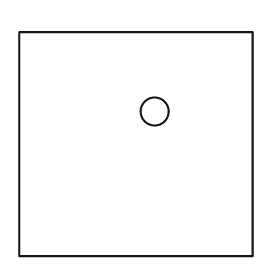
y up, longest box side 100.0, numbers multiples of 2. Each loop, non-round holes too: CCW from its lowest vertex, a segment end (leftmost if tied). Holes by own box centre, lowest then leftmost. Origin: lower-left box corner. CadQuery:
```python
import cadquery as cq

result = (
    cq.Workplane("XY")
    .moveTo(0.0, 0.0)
    .lineTo(100.0, 0.0)
    .lineTo(100.0, 96.0)
    .lineTo(0.0, 96.0)
    .close()
    .moveTo(58.0, 62.0)
    .circle(6.0)
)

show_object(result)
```